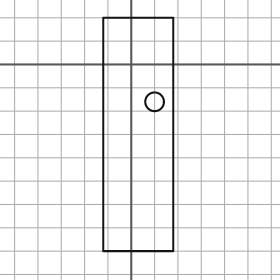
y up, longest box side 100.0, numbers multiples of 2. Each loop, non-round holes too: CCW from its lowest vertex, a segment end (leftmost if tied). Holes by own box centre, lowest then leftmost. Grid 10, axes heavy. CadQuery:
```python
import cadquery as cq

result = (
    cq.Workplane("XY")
    .moveTo(-12.0, -80.0)
    .lineTo(18.0, -80.0)
    .lineTo(18.0, 20.0)
    .lineTo(-12.0, 20.0)
    .close()
    .moveTo(10.0, -16.0)
    .circle(4.0)
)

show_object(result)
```